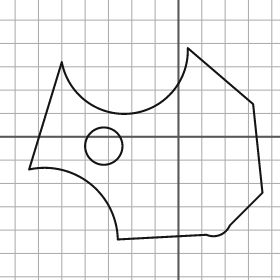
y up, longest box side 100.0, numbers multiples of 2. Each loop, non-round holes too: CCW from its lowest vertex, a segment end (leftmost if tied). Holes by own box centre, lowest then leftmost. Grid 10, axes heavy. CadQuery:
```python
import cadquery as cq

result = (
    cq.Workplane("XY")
    .moveTo(-26.0, -44.0)
    .lineTo(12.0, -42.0)
    .threePointArc((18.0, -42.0), (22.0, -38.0))
    .lineTo(36.0, -24.0)
    .lineTo(32.0, 14.0)
    .lineTo(4.0, 38.0)
    .threePointArc((-20.0, 10.0), (-50.0, 32.0))
    .lineTo(-64.0, -14.0)
    .threePointArc((-38.0, -20.0), (-26.0, -44.0))
    .close()
    .moveTo(-32.0, -4.0)
    .circle(8.0)
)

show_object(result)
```